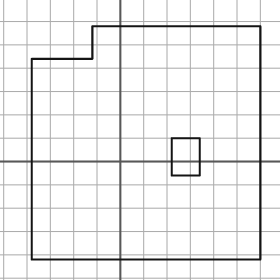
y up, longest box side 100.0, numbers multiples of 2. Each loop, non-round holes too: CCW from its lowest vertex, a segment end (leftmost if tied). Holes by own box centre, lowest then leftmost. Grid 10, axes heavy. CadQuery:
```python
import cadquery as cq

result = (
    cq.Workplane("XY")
    .moveTo(-38.0, -42.0)
    .lineTo(60.0, -42.0)
    .lineTo(60.0, 58.0)
    .lineTo(-12.0, 58.0)
    .lineTo(-12.0, 44.0)
    .lineTo(-38.0, 44.0)
    .close()
    .moveTo(22.0, -6.0)
    .lineTo(34.0, -6.0)
    .lineTo(34.0, 10.0)
    .lineTo(22.0, 10.0)
    .close()
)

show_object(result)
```